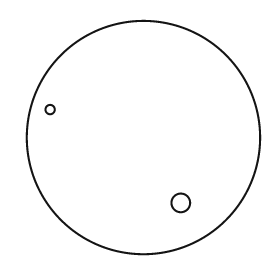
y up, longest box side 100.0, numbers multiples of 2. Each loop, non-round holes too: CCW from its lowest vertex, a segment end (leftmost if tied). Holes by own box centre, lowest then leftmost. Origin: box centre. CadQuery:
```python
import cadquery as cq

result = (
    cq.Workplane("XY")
    .moveTo(0.0, 0.0)
    .circle(50.0)
    .moveTo(16.0, -28.0)
    .circle(4.0)
    .moveTo(-40.0, 12.0)
    .circle(2.0)
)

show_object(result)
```